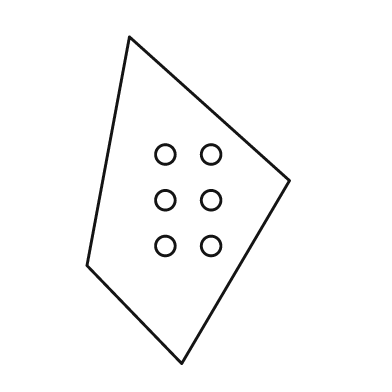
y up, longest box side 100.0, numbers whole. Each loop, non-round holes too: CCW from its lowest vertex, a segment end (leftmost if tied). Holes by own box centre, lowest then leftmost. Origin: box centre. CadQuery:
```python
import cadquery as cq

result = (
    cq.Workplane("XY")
    .moveTo(-2.0, -50.0)
    .lineTo(31.0, 6.0)
    .lineTo(-18.0, 50.0)
    .lineTo(-31.0, -20.0)
    .close()
    .moveTo(-7.0, -14.0)
    .circle(3.0)
    .moveTo(7.0, -14.0)
    .circle(3.0)
    .moveTo(-7.0, 0.0)
    .circle(3.0)
    .moveTo(7.0, 0.0)
    .circle(3.0)
    .moveTo(-7.0, 14.0)
    .circle(3.0)
    .moveTo(7.0, 14.0)
    .circle(3.0)
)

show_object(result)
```